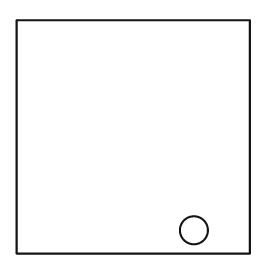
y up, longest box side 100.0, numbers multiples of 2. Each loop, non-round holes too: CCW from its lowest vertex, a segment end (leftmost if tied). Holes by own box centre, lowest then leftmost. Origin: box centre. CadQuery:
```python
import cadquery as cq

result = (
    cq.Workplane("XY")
    .moveTo(-50.0, -50.0)
    .lineTo(50.0, -50.0)
    .lineTo(50.0, 50.0)
    .lineTo(-50.0, 50.0)
    .close()
    .moveTo(26.0, -40.0)
    .circle(6.0)
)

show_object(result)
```